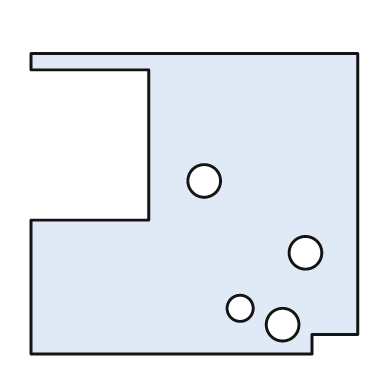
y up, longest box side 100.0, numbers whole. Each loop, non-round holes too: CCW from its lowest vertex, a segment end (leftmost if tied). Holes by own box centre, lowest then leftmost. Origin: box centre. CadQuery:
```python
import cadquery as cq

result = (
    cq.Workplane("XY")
    .moveTo(-50.0, -46.0)
    .lineTo(36.0, -46.0)
    .lineTo(36.0, -40.0)
    .lineTo(50.0, -40.0)
    .lineTo(50.0, 46.0)
    .lineTo(-50.0, 46.0)
    .lineTo(-50.0, 41.0)
    .lineTo(-14.0, 41.0)
    .lineTo(-14.0, -5.0)
    .lineTo(-50.0, -5.0)
    .close()
    .moveTo(27.0, -37.0)
    .circle(5.0)
    .moveTo(14.0, -32.0)
    .circle(4.0)
    .moveTo(34.0, -15.0)
    .circle(5.0)
    .moveTo(3.0, 7.0)
    .circle(5.0)
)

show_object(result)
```